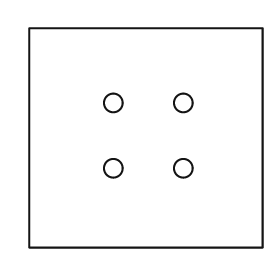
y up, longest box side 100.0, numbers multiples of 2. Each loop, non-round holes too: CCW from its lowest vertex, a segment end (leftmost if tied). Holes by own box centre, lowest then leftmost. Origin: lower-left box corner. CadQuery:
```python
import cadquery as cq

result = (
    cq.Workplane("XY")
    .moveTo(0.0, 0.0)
    .lineTo(100.0, 0.0)
    .lineTo(100.0, 94.0)
    .lineTo(0.0, 94.0)
    .close()
    .moveTo(36.0, 34.0)
    .circle(4.0)
    .moveTo(66.0, 34.0)
    .circle(4.0)
    .moveTo(36.0, 62.0)
    .circle(4.0)
    .moveTo(66.0, 62.0)
    .circle(4.0)
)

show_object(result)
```